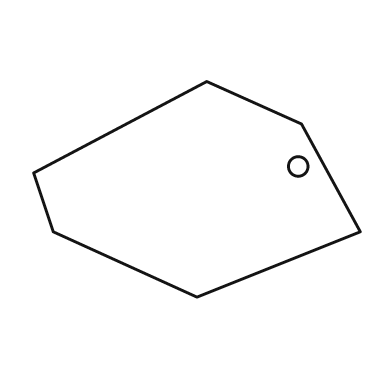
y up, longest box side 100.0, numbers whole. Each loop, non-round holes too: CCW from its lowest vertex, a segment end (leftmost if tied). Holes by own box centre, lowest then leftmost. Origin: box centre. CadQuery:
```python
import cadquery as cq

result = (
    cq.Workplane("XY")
    .moveTo(0.0, -33.0)
    .lineTo(50.0, -13.0)
    .lineTo(32.0, 20.0)
    .lineTo(3.0, 33.0)
    .lineTo(-50.0, 5.0)
    .lineTo(-44.0, -13.0)
    .close()
    .moveTo(31.0, 7.0)
    .circle(3.0)
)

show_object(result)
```